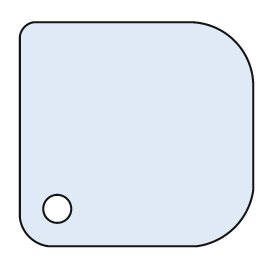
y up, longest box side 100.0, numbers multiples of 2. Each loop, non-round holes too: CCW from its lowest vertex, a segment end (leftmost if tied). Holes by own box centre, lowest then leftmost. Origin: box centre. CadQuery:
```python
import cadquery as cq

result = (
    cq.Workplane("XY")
    .moveTo(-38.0, -48.0)
    .lineTo(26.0, -48.0)
    .threePointArc((42.0, -40.0), (50.0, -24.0))
    .lineTo(50.0, 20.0)
    .threePointArc((42.0, 40.0), (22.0, 48.0))
    .lineTo(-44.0, 48.0)
    .threePointArc((-48.0, 46.0), (-50.0, 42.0))
    .lineTo(-50.0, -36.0)
    .threePointArc((-46.0, -44.0), (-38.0, -48.0))
    .close()
    .moveTo(-34.0, -32.0)
    .circle(6.0)
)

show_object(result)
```